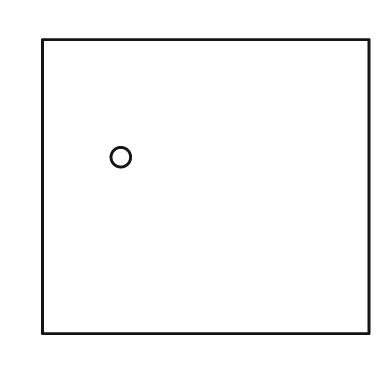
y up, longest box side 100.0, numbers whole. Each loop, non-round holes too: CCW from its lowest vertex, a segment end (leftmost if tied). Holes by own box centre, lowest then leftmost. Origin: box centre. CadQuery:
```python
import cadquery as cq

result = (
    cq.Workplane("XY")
    .moveTo(-50.0, -45.0)
    .lineTo(50.0, -45.0)
    .lineTo(50.0, 45.0)
    .lineTo(-50.0, 45.0)
    .close()
    .moveTo(-26.0, 9.0)
    .circle(3.0)
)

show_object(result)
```